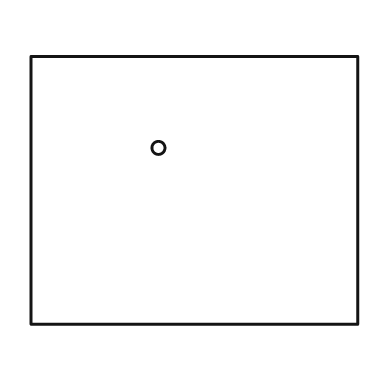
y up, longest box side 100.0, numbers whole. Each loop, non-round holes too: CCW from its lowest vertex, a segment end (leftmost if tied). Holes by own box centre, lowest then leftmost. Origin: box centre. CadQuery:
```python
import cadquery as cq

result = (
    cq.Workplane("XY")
    .moveTo(-50.0, -41.0)
    .lineTo(50.0, -41.0)
    .lineTo(50.0, 41.0)
    .lineTo(-50.0, 41.0)
    .close()
    .moveTo(-11.0, 13.0)
    .circle(2.0)
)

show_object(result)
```